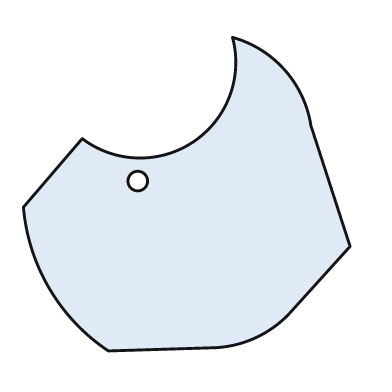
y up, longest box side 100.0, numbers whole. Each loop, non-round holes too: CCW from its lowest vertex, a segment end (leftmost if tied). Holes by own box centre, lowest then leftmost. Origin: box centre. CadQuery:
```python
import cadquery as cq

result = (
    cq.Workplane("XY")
    .moveTo(-24.0, -48.0)
    .lineTo(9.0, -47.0)
    .threePointArc((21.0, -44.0), (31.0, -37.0))
    .lineTo(50.0, -16.0)
    .lineTo(38.0, 21.0)
    .threePointArc((30.0, 38.0), (14.0, 48.0))
    .threePointArc((2.0, 16.0), (-32.0, 17.0))
    .lineTo(-50.0, -4.0)
    .threePointArc((-42.0, -29.0), (-24.0, -48.0))
    .close()
    .moveTo(-15.0, 4.0)
    .circle(3.0)
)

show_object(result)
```